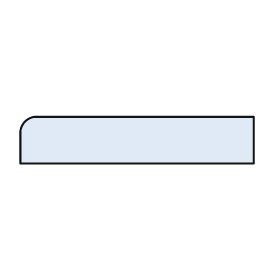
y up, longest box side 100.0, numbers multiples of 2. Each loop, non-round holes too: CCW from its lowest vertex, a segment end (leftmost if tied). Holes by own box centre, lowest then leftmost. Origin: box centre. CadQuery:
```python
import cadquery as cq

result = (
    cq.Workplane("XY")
    .moveTo(-50.0, -10.0)
    .lineTo(50.0, -10.0)
    .lineTo(50.0, 10.0)
    .lineTo(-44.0, 10.0)
    .threePointArc((-48.0, 8.0), (-50.0, 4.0))
    .close()
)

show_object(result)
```